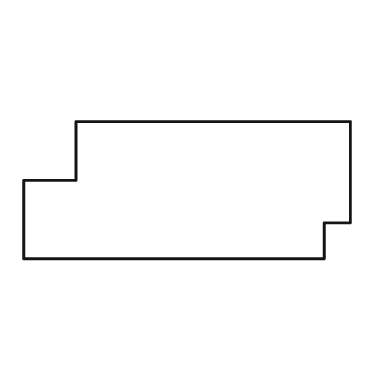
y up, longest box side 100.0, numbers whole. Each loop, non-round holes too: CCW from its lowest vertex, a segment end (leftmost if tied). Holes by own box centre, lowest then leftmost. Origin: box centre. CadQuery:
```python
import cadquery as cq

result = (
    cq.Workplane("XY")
    .moveTo(-50.0, -21.0)
    .lineTo(42.0, -21.0)
    .lineTo(42.0, -10.0)
    .lineTo(50.0, -10.0)
    .lineTo(50.0, 21.0)
    .lineTo(-34.0, 21.0)
    .lineTo(-34.0, 3.0)
    .lineTo(-50.0, 3.0)
    .close()
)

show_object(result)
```